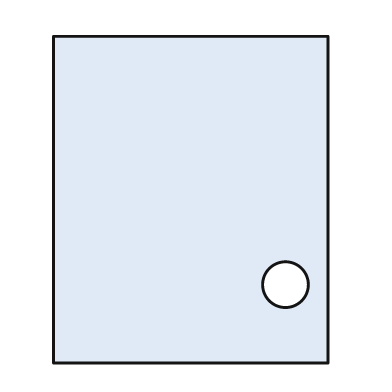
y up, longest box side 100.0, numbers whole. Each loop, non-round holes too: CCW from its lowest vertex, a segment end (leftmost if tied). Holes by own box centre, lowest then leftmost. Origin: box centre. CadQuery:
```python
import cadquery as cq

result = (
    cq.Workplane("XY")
    .moveTo(-42.0, -50.0)
    .lineTo(42.0, -50.0)
    .lineTo(42.0, 50.0)
    .lineTo(-42.0, 50.0)
    .close()
    .moveTo(29.0, -26.0)
    .circle(7.0)
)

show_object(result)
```